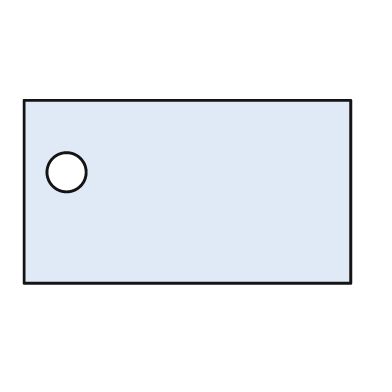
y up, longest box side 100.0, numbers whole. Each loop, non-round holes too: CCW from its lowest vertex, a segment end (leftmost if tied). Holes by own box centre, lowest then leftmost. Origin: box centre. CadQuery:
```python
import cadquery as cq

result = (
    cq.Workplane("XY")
    .moveTo(-50.0, -28.0)
    .lineTo(50.0, -28.0)
    .lineTo(50.0, 28.0)
    .lineTo(-50.0, 28.0)
    .close()
    .moveTo(-37.0, 6.0)
    .circle(6.0)
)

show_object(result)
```